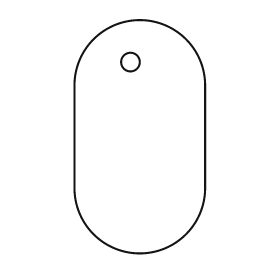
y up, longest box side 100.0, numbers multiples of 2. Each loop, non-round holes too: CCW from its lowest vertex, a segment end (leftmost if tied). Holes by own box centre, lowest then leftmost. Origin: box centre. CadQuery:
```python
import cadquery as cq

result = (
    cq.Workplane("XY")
    .moveTo(-28.0, -22.0)
    .threePointArc((0.0, -50.0), (28.0, -22.0))
    .lineTo(28.0, 22.0)
    .threePointArc((0.0, 50.0), (-28.0, 22.0))
    .close()
    .moveTo(-4.0, 32.0)
    .circle(4.0)
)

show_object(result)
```